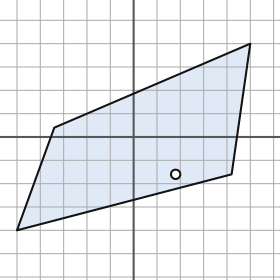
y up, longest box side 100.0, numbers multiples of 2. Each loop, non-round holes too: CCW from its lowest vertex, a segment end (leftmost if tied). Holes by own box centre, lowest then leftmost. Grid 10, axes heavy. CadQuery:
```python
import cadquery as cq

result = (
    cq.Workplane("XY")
    .moveTo(-50.0, -40.0)
    .lineTo(42.0, -16.0)
    .lineTo(50.0, 40.0)
    .lineTo(-34.0, 4.0)
    .close()
    .moveTo(18.0, -16.0)
    .circle(2.0)
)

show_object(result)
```